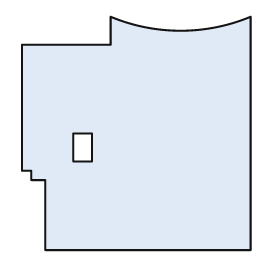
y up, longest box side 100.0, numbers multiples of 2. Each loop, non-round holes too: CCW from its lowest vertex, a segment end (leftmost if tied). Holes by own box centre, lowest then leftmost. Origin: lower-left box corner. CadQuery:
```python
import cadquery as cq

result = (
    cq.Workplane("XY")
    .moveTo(10.0, 0.0)
    .lineTo(98.0, 0.0)
    .lineTo(98.0, 100.0)
    .threePointArc((68.0, 94.0), (38.0, 100.0))
    .lineTo(38.0, 88.0)
    .lineTo(0.0, 88.0)
    .lineTo(0.0, 34.0)
    .lineTo(4.0, 34.0)
    .lineTo(4.0, 30.0)
    .lineTo(10.0, 30.0)
    .close()
    .moveTo(22.0, 38.0)
    .lineTo(30.0, 38.0)
    .lineTo(30.0, 50.0)
    .lineTo(22.0, 50.0)
    .close()
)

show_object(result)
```